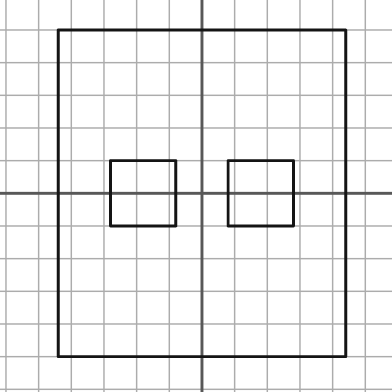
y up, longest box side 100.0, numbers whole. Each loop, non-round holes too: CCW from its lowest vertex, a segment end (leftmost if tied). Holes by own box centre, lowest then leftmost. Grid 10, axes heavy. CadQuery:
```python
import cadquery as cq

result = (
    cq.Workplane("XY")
    .moveTo(-44.0, -50.0)
    .lineTo(44.0, -50.0)
    .lineTo(44.0, 50.0)
    .lineTo(-44.0, 50.0)
    .close()
    .moveTo(-28.0, -10.0)
    .lineTo(-8.0, -10.0)
    .lineTo(-8.0, 10.0)
    .lineTo(-28.0, 10.0)
    .close()
    .moveTo(8.0, -10.0)
    .lineTo(28.0, -10.0)
    .lineTo(28.0, 10.0)
    .lineTo(8.0, 10.0)
    .close()
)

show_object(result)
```